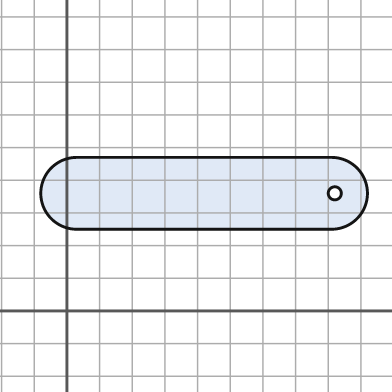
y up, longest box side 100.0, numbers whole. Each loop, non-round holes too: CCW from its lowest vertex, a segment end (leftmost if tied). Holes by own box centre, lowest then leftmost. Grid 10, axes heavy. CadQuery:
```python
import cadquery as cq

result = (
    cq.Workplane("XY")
    .moveTo(3.0, 25.0)
    .lineTo(81.0, 25.0)
    .threePointArc((92.0, 36.0), (81.0, 47.0))
    .lineTo(3.0, 47.0)
    .threePointArc((-8.0, 36.0), (3.0, 25.0))
    .close()
    .moveTo(82.0, 36.0)
    .circle(2.0)
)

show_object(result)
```